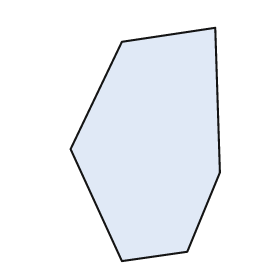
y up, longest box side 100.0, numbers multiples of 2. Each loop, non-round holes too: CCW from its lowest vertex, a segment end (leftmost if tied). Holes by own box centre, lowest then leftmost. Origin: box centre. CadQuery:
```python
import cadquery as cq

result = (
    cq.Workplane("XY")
    .moveTo(-10.0, -50.0)
    .lineTo(18.0, -46.0)
    .lineTo(32.0, -12.0)
    .lineTo(30.0, 50.0)
    .lineTo(-10.0, 44.0)
    .lineTo(-32.0, -2.0)
    .close()
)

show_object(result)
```